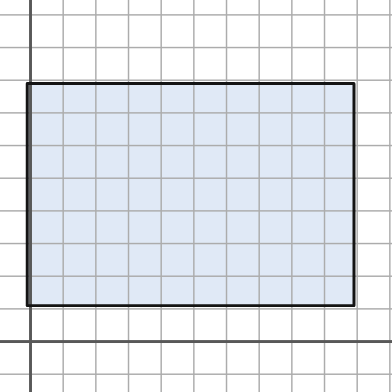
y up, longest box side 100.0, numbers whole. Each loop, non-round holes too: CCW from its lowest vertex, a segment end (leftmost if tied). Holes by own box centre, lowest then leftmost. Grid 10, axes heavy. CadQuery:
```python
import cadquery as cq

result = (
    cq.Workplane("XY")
    .moveTo(-1.0, 11.0)
    .lineTo(99.0, 11.0)
    .lineTo(99.0, 79.0)
    .lineTo(-1.0, 79.0)
    .close()
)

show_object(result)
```